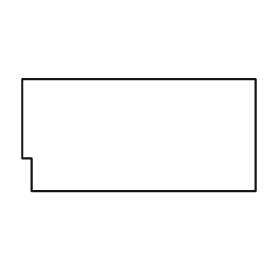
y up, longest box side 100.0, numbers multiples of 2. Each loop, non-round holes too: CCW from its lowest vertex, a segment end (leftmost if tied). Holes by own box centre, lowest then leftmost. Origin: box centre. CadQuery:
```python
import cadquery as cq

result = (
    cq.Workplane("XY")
    .moveTo(-46.0, -24.0)
    .lineTo(50.0, -24.0)
    .lineTo(50.0, 24.0)
    .lineTo(-50.0, 24.0)
    .lineTo(-50.0, -10.0)
    .lineTo(-46.0, -10.0)
    .close()
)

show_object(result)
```